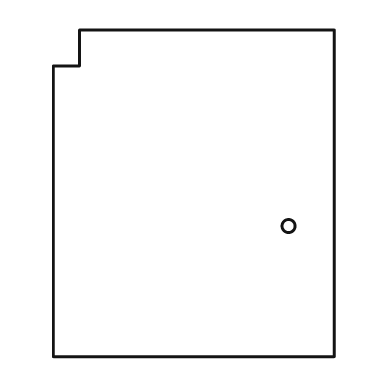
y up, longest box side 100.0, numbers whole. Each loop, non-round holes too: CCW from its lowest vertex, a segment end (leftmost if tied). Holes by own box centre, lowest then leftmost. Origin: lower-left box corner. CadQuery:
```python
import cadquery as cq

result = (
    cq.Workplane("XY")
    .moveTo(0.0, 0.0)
    .lineTo(86.0, 0.0)
    .lineTo(86.0, 100.0)
    .lineTo(8.0, 100.0)
    .lineTo(8.0, 89.0)
    .lineTo(0.0, 89.0)
    .close()
    .moveTo(72.0, 40.0)
    .circle(2.0)
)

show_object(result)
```